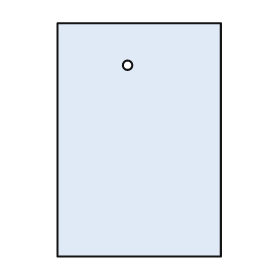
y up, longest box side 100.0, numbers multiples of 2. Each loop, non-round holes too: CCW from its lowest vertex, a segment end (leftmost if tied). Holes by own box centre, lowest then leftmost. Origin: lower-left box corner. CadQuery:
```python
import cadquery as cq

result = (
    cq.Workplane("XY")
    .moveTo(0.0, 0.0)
    .lineTo(70.0, 0.0)
    .lineTo(70.0, 100.0)
    .lineTo(0.0, 100.0)
    .close()
    .moveTo(30.0, 82.0)
    .circle(2.0)
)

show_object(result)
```